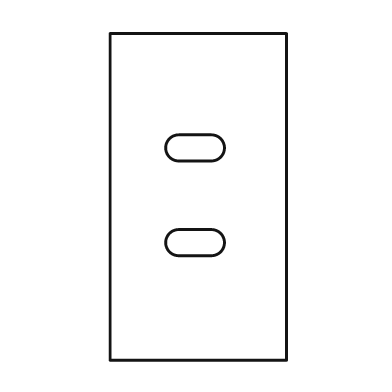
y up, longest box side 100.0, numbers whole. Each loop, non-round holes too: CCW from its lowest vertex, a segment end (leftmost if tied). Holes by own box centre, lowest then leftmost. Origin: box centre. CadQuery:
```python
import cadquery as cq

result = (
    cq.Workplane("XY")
    .moveTo(-27.0, -50.0)
    .lineTo(27.0, -50.0)
    .lineTo(27.0, 50.0)
    .lineTo(-27.0, 50.0)
    .close()
    .moveTo(-6.0, -18.0)
    .lineTo(4.0, -18.0)
    .threePointArc((8.0, -14.0), (4.0, -10.0))
    .lineTo(-6.0, -10.0)
    .threePointArc((-10.0, -14.0), (-6.0, -18.0))
    .close()
    .moveTo(-6.0, 11.0)
    .lineTo(4.0, 11.0)
    .threePointArc((8.0, 15.0), (4.0, 19.0))
    .lineTo(-6.0, 19.0)
    .threePointArc((-10.0, 15.0), (-6.0, 11.0))
    .close()
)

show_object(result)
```